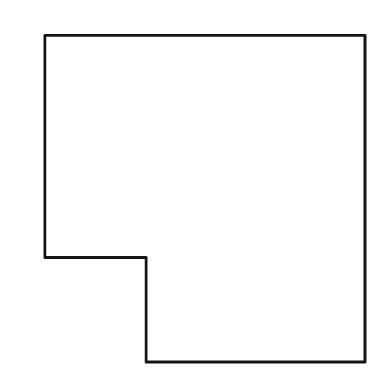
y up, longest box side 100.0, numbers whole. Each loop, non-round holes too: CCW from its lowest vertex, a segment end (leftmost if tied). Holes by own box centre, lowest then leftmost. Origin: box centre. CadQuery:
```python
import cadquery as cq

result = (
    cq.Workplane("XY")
    .moveTo(-18.0, -50.0)
    .lineTo(49.0, -50.0)
    .lineTo(49.0, 50.0)
    .lineTo(-49.0, 50.0)
    .lineTo(-49.0, -18.0)
    .lineTo(-18.0, -18.0)
    .close()
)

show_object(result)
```